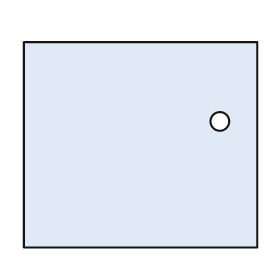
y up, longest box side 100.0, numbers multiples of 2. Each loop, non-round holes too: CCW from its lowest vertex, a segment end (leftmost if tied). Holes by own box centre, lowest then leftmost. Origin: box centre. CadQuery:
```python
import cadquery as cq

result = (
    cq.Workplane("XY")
    .moveTo(-50.0, -44.0)
    .lineTo(50.0, -44.0)
    .lineTo(50.0, 44.0)
    .lineTo(-50.0, 44.0)
    .close()
    .moveTo(34.0, 10.0)
    .circle(4.0)
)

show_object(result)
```